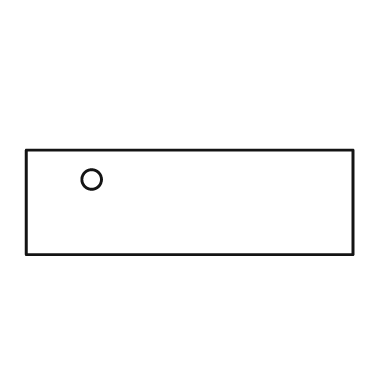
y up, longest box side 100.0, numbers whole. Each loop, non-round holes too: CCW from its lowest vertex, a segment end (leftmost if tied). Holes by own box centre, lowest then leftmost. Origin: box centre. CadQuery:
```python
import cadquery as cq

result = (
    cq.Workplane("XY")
    .moveTo(-50.0, -16.0)
    .lineTo(50.0, -16.0)
    .lineTo(50.0, 16.0)
    .lineTo(-50.0, 16.0)
    .close()
    .moveTo(-30.0, 7.0)
    .circle(3.0)
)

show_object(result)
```